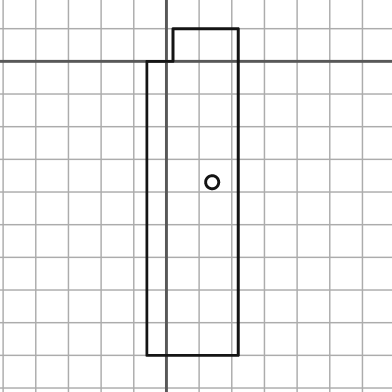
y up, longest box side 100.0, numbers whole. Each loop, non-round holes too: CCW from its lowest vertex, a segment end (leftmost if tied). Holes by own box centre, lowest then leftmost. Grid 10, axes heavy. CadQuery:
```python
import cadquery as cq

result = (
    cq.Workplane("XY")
    .moveTo(-6.0, -90.0)
    .lineTo(22.0, -90.0)
    .lineTo(22.0, 10.0)
    .lineTo(2.0, 10.0)
    .lineTo(2.0, 0.0)
    .lineTo(-6.0, 0.0)
    .close()
    .moveTo(14.0, -37.0)
    .circle(2.0)
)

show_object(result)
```